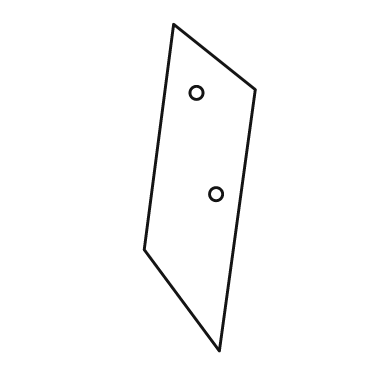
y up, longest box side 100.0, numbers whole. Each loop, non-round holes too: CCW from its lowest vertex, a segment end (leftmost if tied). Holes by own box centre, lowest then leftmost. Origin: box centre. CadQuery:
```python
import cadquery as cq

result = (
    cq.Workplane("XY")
    .moveTo(6.0, -50.0)
    .lineTo(17.0, 30.0)
    .lineTo(-8.0, 50.0)
    .lineTo(-17.0, -19.0)
    .close()
    .moveTo(5.0, -2.0)
    .circle(2.0)
    .moveTo(-1.0, 29.0)
    .circle(2.0)
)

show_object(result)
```